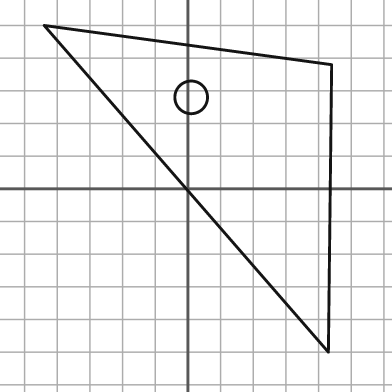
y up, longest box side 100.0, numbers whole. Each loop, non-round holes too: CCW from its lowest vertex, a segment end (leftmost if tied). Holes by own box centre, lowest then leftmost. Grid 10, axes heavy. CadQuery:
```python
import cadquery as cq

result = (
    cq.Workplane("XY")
    .moveTo(43.0, -50.0)
    .lineTo(44.0, 38.0)
    .lineTo(-44.0, 50.0)
    .close()
    .moveTo(1.0, 28.0)
    .circle(5.0)
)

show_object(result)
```